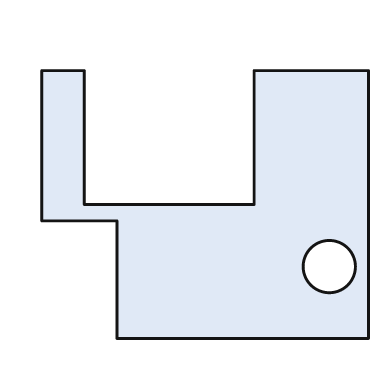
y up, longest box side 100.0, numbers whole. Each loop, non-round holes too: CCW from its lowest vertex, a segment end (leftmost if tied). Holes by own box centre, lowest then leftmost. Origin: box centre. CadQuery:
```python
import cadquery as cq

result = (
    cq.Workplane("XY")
    .moveTo(-27.0, -41.0)
    .lineTo(50.0, -41.0)
    .lineTo(50.0, 41.0)
    .lineTo(15.0, 41.0)
    .lineTo(15.0, 0.0)
    .lineTo(-37.0, 0.0)
    .lineTo(-37.0, 41.0)
    .lineTo(-50.0, 41.0)
    .lineTo(-50.0, -5.0)
    .lineTo(-27.0, -5.0)
    .close()
    .moveTo(38.0, -19.0)
    .circle(8.0)
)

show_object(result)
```